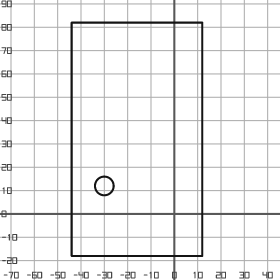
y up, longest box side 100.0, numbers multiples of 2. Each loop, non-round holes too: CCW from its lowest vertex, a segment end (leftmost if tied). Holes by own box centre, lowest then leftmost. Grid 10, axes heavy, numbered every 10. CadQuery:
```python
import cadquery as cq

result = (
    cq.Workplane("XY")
    .moveTo(-44.0, -18.0)
    .lineTo(12.0, -18.0)
    .lineTo(12.0, 82.0)
    .lineTo(-44.0, 82.0)
    .close()
    .moveTo(-30.0, 12.0)
    .circle(4.0)
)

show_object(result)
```